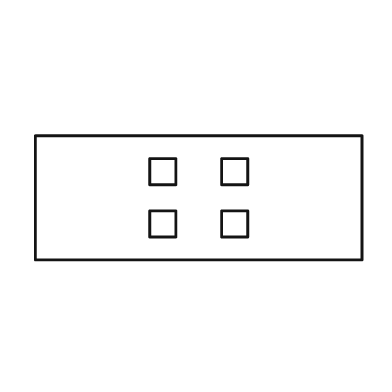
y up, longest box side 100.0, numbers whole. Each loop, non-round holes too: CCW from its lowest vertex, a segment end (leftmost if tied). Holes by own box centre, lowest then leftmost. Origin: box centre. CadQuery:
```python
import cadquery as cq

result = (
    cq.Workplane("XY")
    .moveTo(-50.0, -19.0)
    .lineTo(50.0, -19.0)
    .lineTo(50.0, 19.0)
    .lineTo(-50.0, 19.0)
    .close()
    .moveTo(-15.0, -12.0)
    .lineTo(-7.0, -12.0)
    .lineTo(-7.0, -4.0)
    .lineTo(-15.0, -4.0)
    .close()
    .moveTo(7.0, -12.0)
    .lineTo(15.0, -12.0)
    .lineTo(15.0, -4.0)
    .lineTo(7.0, -4.0)
    .close()
    .moveTo(-15.0, 4.0)
    .lineTo(-7.0, 4.0)
    .lineTo(-7.0, 12.0)
    .lineTo(-15.0, 12.0)
    .close()
    .moveTo(7.0, 4.0)
    .lineTo(15.0, 4.0)
    .lineTo(15.0, 12.0)
    .lineTo(7.0, 12.0)
    .close()
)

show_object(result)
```